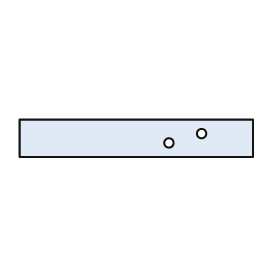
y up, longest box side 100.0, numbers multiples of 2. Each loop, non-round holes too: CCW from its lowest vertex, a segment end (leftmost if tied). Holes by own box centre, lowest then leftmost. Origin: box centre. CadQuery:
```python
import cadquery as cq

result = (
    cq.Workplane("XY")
    .moveTo(-50.0, -8.0)
    .lineTo(50.0, -8.0)
    .lineTo(50.0, 8.0)
    .lineTo(-50.0, 8.0)
    .close()
    .moveTo(14.0, -2.0)
    .circle(2.0)
    .moveTo(28.0, 2.0)
    .circle(2.0)
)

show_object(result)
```